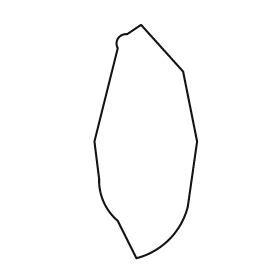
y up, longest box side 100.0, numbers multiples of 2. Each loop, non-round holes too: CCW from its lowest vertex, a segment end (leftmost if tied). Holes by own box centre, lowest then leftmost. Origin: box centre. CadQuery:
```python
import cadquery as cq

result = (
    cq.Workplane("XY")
    .moveTo(-4.0, -50.0)
    .threePointArc((10.0, -42.0), (18.0, -28.0))
    .lineTo(22.0, 0.0)
    .lineTo(16.0, 30.0)
    .lineTo(-2.0, 50.0)
    .lineTo(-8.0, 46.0)
    .threePointArc((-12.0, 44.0), (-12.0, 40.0))
    .lineTo(-22.0, 0.0)
    .lineTo(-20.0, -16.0)
    .threePointArc((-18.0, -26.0), (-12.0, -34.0))
    .close()
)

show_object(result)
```